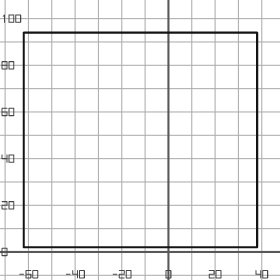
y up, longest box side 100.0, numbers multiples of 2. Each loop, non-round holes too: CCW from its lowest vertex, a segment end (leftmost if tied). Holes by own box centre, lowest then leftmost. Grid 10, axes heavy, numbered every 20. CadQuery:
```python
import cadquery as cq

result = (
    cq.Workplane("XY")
    .moveTo(-62.0, 2.0)
    .lineTo(38.0, 2.0)
    .lineTo(38.0, 94.0)
    .lineTo(-62.0, 94.0)
    .close()
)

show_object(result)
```